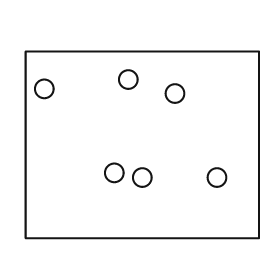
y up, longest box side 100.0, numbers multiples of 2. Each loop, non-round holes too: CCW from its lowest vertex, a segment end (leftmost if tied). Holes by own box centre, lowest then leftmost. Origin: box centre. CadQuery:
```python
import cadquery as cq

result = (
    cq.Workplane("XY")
    .moveTo(-50.0, -40.0)
    .lineTo(50.0, -40.0)
    .lineTo(50.0, 40.0)
    .lineTo(-50.0, 40.0)
    .close()
    .moveTo(0.0, -14.0)
    .circle(4.0)
    .moveTo(32.0, -14.0)
    .circle(4.0)
    .moveTo(-12.0, -12.0)
    .circle(4.0)
    .moveTo(14.0, 22.0)
    .circle(4.0)
    .moveTo(-42.0, 24.0)
    .circle(4.0)
    .moveTo(-6.0, 28.0)
    .circle(4.0)
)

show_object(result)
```